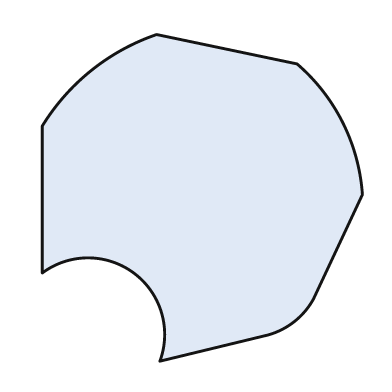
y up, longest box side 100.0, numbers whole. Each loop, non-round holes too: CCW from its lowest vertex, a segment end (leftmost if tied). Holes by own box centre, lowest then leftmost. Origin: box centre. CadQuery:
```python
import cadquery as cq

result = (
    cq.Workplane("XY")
    .moveTo(-13.0, -50.0)
    .lineTo(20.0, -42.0)
    .threePointArc((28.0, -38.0), (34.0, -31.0))
    .lineTo(49.0, 1.0)
    .threePointArc((43.0, 23.0), (29.0, 41.0))
    .lineTo(-14.0, 50.0)
    .threePointArc((-34.0, 39.0), (-49.0, 22.0))
    .lineTo(-49.0, -23.0)
    .threePointArc((-21.0, -23.0), (-13.0, -50.0))
    .close()
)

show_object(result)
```